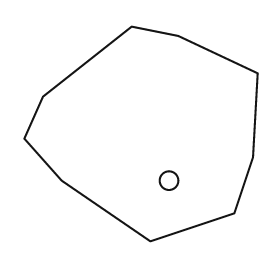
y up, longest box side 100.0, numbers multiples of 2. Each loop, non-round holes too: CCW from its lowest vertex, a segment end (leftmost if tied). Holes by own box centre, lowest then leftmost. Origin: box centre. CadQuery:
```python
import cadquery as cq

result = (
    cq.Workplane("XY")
    .moveTo(4.0, -46.0)
    .lineTo(40.0, -34.0)
    .lineTo(48.0, -10.0)
    .lineTo(50.0, 26.0)
    .lineTo(16.0, 42.0)
    .lineTo(-4.0, 46.0)
    .lineTo(-42.0, 16.0)
    .lineTo(-50.0, -2.0)
    .lineTo(-34.0, -20.0)
    .close()
    .moveTo(12.0, -20.0)
    .circle(4.0)
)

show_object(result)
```